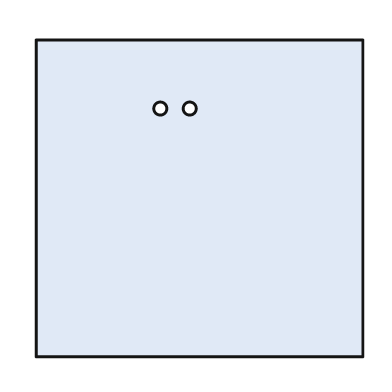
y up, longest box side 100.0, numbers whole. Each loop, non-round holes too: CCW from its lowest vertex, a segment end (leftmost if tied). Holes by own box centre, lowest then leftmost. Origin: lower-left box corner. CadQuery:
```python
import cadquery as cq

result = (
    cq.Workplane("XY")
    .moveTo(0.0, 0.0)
    .lineTo(100.0, 0.0)
    .lineTo(100.0, 97.0)
    .lineTo(0.0, 97.0)
    .close()
    .moveTo(38.0, 76.0)
    .circle(2.0)
    .moveTo(47.0, 76.0)
    .circle(2.0)
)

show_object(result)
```